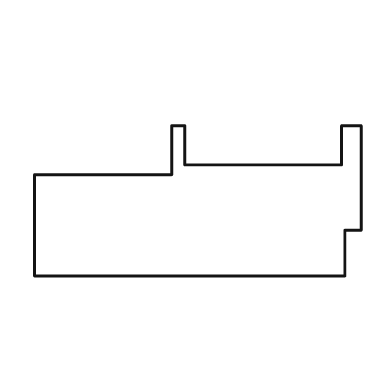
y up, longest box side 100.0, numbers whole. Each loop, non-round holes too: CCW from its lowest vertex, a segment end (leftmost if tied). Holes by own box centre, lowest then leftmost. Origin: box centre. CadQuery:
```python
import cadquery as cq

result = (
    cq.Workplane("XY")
    .moveTo(-50.0, -23.0)
    .lineTo(45.0, -23.0)
    .lineTo(45.0, -9.0)
    .lineTo(50.0, -9.0)
    .lineTo(50.0, 23.0)
    .lineTo(44.0, 23.0)
    .lineTo(44.0, 11.0)
    .lineTo(-4.0, 11.0)
    .lineTo(-4.0, 23.0)
    .lineTo(-8.0, 23.0)
    .lineTo(-8.0, 8.0)
    .lineTo(-50.0, 8.0)
    .close()
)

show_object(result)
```